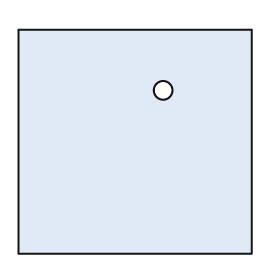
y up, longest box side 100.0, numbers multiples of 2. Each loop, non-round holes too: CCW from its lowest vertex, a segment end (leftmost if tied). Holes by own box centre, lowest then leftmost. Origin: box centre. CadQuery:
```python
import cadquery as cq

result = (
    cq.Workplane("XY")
    .moveTo(-50.0, -48.0)
    .lineTo(50.0, -48.0)
    .lineTo(50.0, 48.0)
    .lineTo(-50.0, 48.0)
    .close()
    .moveTo(12.0, 22.0)
    .circle(4.0)
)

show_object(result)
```